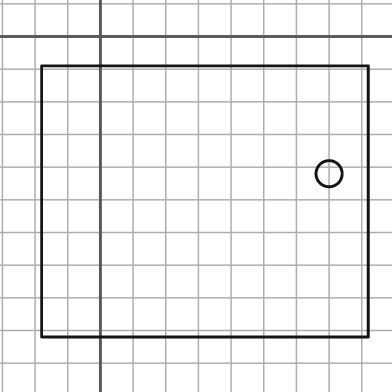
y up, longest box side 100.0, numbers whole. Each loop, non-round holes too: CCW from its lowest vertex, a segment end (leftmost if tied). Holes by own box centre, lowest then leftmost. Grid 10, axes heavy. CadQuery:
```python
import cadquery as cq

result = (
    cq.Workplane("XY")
    .moveTo(-18.0, -92.0)
    .lineTo(82.0, -92.0)
    .lineTo(82.0, -9.0)
    .lineTo(-18.0, -9.0)
    .close()
    .moveTo(70.0, -42.0)
    .circle(4.0)
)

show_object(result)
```